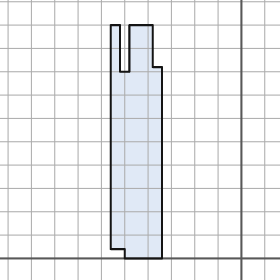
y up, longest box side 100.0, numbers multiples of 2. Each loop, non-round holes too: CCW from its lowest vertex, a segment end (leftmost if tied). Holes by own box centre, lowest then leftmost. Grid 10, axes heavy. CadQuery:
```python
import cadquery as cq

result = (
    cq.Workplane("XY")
    .moveTo(-50.0, 0.0)
    .lineTo(-34.0, 0.0)
    .lineTo(-34.0, 82.0)
    .lineTo(-38.0, 82.0)
    .lineTo(-38.0, 100.0)
    .lineTo(-48.0, 100.0)
    .lineTo(-48.0, 80.0)
    .lineTo(-52.0, 80.0)
    .lineTo(-52.0, 100.0)
    .lineTo(-56.0, 100.0)
    .lineTo(-56.0, 4.0)
    .lineTo(-50.0, 4.0)
    .close()
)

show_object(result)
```